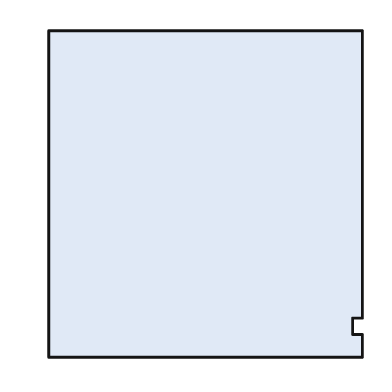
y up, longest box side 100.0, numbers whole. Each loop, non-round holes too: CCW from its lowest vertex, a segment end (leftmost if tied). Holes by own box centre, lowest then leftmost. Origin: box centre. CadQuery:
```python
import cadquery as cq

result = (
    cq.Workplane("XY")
    .moveTo(-48.0, -50.0)
    .lineTo(48.0, -50.0)
    .lineTo(48.0, -43.0)
    .lineTo(45.0, -43.0)
    .lineTo(45.0, -38.0)
    .lineTo(48.0, -38.0)
    .lineTo(48.0, 50.0)
    .lineTo(-48.0, 50.0)
    .close()
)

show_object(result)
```